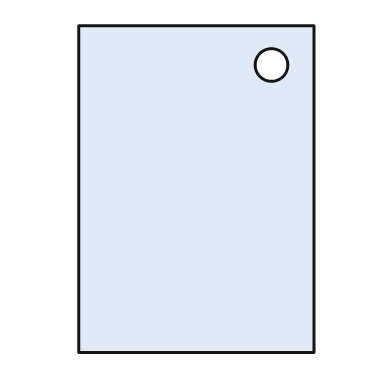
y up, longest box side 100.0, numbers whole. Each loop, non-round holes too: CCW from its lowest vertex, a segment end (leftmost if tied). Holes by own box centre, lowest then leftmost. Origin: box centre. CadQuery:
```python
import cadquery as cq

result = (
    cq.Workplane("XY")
    .moveTo(-36.0, -50.0)
    .lineTo(36.0, -50.0)
    .lineTo(36.0, 50.0)
    .lineTo(-36.0, 50.0)
    .close()
    .moveTo(23.0, 38.0)
    .circle(5.0)
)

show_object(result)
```